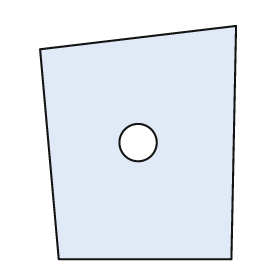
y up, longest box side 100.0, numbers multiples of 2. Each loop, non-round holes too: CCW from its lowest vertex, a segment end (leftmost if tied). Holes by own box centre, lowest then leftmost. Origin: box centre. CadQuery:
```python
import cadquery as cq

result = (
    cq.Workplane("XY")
    .moveTo(-34.0, -50.0)
    .lineTo(40.0, -50.0)
    .lineTo(42.0, 50.0)
    .lineTo(-42.0, 40.0)
    .close()
    .moveTo(0.0, 0.0)
    .circle(8.0)
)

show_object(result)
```